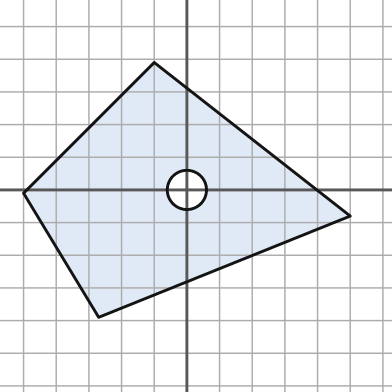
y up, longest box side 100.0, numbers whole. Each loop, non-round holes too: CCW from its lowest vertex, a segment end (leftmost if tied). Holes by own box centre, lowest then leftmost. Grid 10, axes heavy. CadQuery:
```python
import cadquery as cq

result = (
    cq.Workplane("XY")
    .moveTo(-27.0, -39.0)
    .lineTo(50.0, -8.0)
    .lineTo(-10.0, 39.0)
    .lineTo(-50.0, -1.0)
    .close()
    .moveTo(0.0, 0.0)
    .circle(6.0)
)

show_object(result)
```